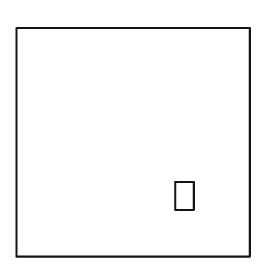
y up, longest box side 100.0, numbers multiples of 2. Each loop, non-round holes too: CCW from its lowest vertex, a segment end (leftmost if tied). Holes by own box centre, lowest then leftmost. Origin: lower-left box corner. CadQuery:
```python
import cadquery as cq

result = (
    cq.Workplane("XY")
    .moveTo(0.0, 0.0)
    .lineTo(100.0, 0.0)
    .lineTo(100.0, 98.0)
    .lineTo(0.0, 98.0)
    .close()
    .moveTo(68.0, 20.0)
    .lineTo(76.0, 20.0)
    .lineTo(76.0, 32.0)
    .lineTo(68.0, 32.0)
    .close()
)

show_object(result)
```